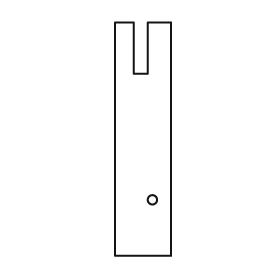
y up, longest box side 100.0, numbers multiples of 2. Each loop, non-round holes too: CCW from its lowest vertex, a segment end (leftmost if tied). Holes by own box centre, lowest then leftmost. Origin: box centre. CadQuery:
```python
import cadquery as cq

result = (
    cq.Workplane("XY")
    .moveTo(-12.0, -50.0)
    .lineTo(12.0, -50.0)
    .lineTo(12.0, 50.0)
    .lineTo(2.0, 50.0)
    .lineTo(2.0, 28.0)
    .lineTo(-4.0, 28.0)
    .lineTo(-4.0, 50.0)
    .lineTo(-12.0, 50.0)
    .close()
    .moveTo(4.0, -26.0)
    .circle(2.0)
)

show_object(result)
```